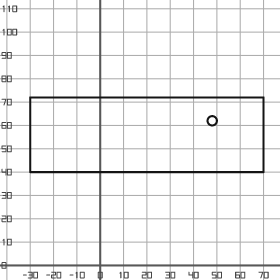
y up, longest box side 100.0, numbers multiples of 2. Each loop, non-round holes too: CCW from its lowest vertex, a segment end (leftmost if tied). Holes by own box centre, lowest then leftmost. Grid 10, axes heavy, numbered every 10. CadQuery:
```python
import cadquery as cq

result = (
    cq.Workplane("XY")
    .moveTo(-30.0, 40.0)
    .lineTo(70.0, 40.0)
    .lineTo(70.0, 72.0)
    .lineTo(-30.0, 72.0)
    .close()
    .moveTo(48.0, 62.0)
    .circle(2.0)
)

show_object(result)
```